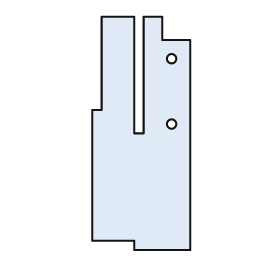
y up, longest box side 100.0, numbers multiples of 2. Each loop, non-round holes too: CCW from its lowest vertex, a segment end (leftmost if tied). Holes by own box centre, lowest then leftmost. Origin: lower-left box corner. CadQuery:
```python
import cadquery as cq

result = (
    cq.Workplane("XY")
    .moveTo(18.0, 0.0)
    .lineTo(42.0, 0.0)
    .lineTo(42.0, 90.0)
    .lineTo(30.0, 90.0)
    .lineTo(30.0, 100.0)
    .lineTo(22.0, 100.0)
    .lineTo(22.0, 50.0)
    .lineTo(18.0, 50.0)
    .lineTo(18.0, 100.0)
    .lineTo(4.0, 100.0)
    .lineTo(4.0, 60.0)
    .lineTo(0.0, 60.0)
    .lineTo(0.0, 4.0)
    .lineTo(18.0, 4.0)
    .close()
    .moveTo(34.0, 54.0)
    .circle(2.0)
    .moveTo(34.0, 82.0)
    .circle(2.0)
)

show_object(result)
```